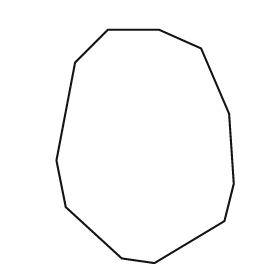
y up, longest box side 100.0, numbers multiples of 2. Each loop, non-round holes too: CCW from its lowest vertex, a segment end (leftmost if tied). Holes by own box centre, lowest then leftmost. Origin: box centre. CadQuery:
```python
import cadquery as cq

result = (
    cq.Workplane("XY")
    .moveTo(4.0, -50.0)
    .lineTo(34.0, -32.0)
    .lineTo(38.0, -16.0)
    .lineTo(36.0, 14.0)
    .lineTo(24.0, 42.0)
    .lineTo(6.0, 50.0)
    .lineTo(-16.0, 50.0)
    .lineTo(-30.0, 36.0)
    .lineTo(-38.0, -6.0)
    .lineTo(-34.0, -26.0)
    .lineTo(-10.0, -48.0)
    .close()
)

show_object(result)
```